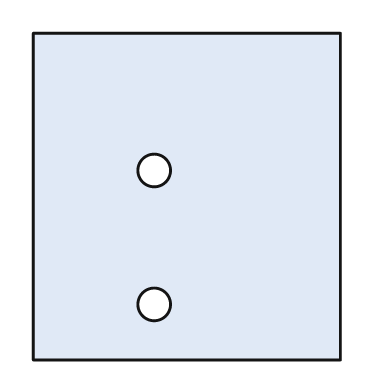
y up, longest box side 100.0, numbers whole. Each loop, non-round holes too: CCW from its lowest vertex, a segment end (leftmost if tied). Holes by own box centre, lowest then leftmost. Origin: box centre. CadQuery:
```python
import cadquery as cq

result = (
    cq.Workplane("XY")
    .moveTo(-47.0, -50.0)
    .lineTo(47.0, -50.0)
    .lineTo(47.0, 50.0)
    .lineTo(-47.0, 50.0)
    .close()
    .moveTo(-10.0, -33.0)
    .circle(5.0)
    .moveTo(-10.0, 8.0)
    .circle(5.0)
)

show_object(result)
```